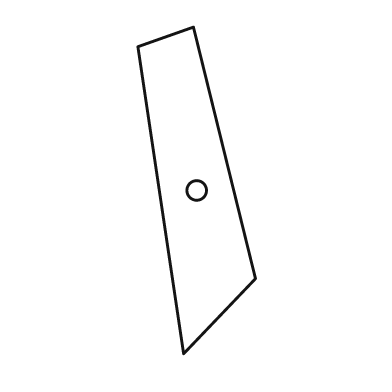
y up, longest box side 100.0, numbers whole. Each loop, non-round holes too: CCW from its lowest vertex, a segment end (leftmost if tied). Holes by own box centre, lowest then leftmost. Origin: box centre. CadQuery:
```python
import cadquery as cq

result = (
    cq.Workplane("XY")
    .moveTo(-4.0, -50.0)
    .lineTo(18.0, -27.0)
    .lineTo(-1.0, 50.0)
    .lineTo(-18.0, 44.0)
    .close()
    .moveTo(0.0, 0.0)
    .circle(3.0)
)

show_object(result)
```